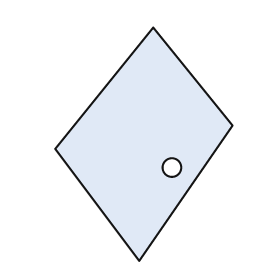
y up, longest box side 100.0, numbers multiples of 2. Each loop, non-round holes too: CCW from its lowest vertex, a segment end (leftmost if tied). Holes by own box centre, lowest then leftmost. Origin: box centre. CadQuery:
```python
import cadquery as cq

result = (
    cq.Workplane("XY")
    .moveTo(-2.0, -50.0)
    .lineTo(38.0, 8.0)
    .lineTo(4.0, 50.0)
    .lineTo(-38.0, -2.0)
    .close()
    .moveTo(12.0, -10.0)
    .circle(4.0)
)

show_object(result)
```